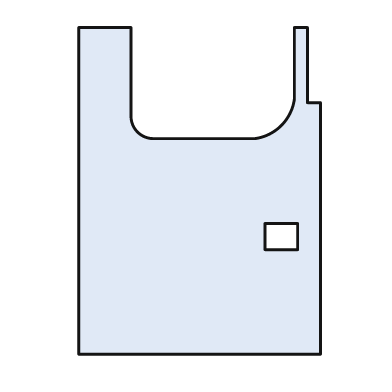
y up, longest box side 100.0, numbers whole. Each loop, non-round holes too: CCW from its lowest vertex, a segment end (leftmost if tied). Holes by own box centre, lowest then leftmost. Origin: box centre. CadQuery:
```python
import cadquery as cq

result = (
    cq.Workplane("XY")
    .moveTo(-37.0, -50.0)
    .lineTo(37.0, -50.0)
    .lineTo(37.0, 27.0)
    .lineTo(33.0, 27.0)
    .lineTo(33.0, 50.0)
    .lineTo(29.0, 50.0)
    .lineTo(29.0, 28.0)
    .threePointArc((25.0, 20.0), (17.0, 16.0))
    .lineTo(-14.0, 16.0)
    .threePointArc((-19.0, 18.0), (-21.0, 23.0))
    .lineTo(-21.0, 50.0)
    .lineTo(-37.0, 50.0)
    .close()
    .moveTo(20.0, -18.0)
    .lineTo(30.0, -18.0)
    .lineTo(30.0, -10.0)
    .lineTo(20.0, -10.0)
    .close()
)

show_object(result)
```